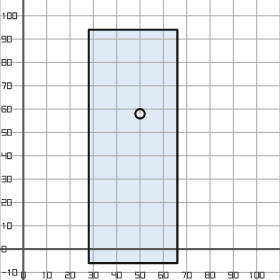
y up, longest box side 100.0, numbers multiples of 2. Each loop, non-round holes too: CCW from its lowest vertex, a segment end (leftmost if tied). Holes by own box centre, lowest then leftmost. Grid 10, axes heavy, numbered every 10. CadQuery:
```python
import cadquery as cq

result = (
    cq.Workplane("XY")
    .moveTo(28.0, -6.0)
    .lineTo(66.0, -6.0)
    .lineTo(66.0, 94.0)
    .lineTo(28.0, 94.0)
    .close()
    .moveTo(50.0, 58.0)
    .circle(2.0)
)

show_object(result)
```